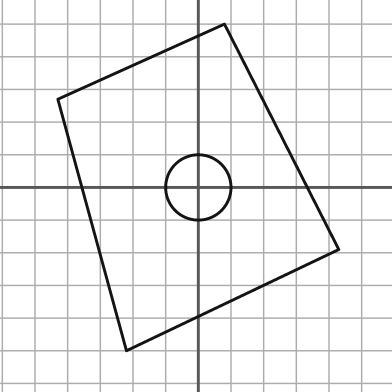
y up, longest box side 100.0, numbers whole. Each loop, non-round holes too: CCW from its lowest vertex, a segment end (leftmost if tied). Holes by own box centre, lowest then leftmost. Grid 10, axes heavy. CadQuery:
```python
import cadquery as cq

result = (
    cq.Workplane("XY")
    .moveTo(-22.0, -50.0)
    .lineTo(43.0, -19.0)
    .lineTo(8.0, 50.0)
    .lineTo(-43.0, 27.0)
    .close()
    .moveTo(0.0, 0.0)
    .circle(10.0)
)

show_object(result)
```